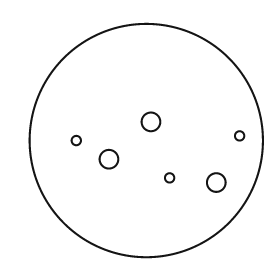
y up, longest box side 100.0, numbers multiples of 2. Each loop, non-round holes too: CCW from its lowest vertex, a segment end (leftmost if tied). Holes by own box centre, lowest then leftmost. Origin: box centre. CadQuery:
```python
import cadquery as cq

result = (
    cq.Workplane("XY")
    .moveTo(0.0, 0.0)
    .circle(50.0)
    .moveTo(30.0, -18.0)
    .circle(4.0)
    .moveTo(10.0, -16.0)
    .circle(2.0)
    .moveTo(-16.0, -8.0)
    .circle(4.0)
    .moveTo(-30.0, 0.0)
    .circle(2.0)
    .moveTo(40.0, 2.0)
    .circle(2.0)
    .moveTo(2.0, 8.0)
    .circle(4.0)
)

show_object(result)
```